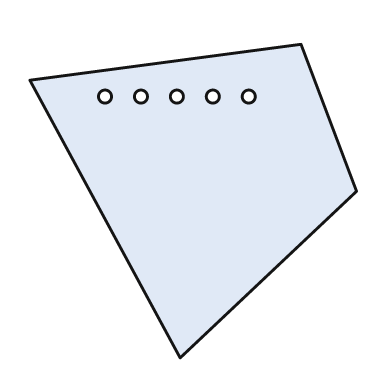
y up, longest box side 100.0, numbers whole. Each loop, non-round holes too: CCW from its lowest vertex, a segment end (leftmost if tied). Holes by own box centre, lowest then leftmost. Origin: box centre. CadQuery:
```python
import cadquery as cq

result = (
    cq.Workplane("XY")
    .moveTo(-4.0, -48.0)
    .lineTo(50.0, 3.0)
    .lineTo(33.0, 48.0)
    .lineTo(-50.0, 37.0)
    .close()
    .moveTo(-27.0, 32.0)
    .circle(2.0)
    .moveTo(-16.0, 32.0)
    .circle(2.0)
    .moveTo(-5.0, 32.0)
    .circle(2.0)
    .moveTo(6.0, 32.0)
    .circle(2.0)
    .moveTo(17.0, 32.0)
    .circle(2.0)
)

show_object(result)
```